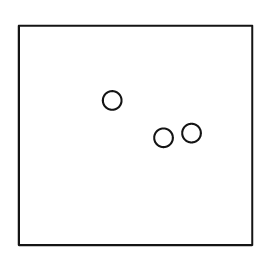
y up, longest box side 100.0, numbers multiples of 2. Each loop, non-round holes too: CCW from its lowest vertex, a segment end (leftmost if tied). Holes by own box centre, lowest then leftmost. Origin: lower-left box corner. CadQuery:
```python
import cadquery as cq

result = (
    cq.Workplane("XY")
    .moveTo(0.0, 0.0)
    .lineTo(100.0, 0.0)
    .lineTo(100.0, 94.0)
    .lineTo(0.0, 94.0)
    .close()
    .moveTo(62.0, 46.0)
    .circle(4.0)
    .moveTo(74.0, 48.0)
    .circle(4.0)
    .moveTo(40.0, 62.0)
    .circle(4.0)
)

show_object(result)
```